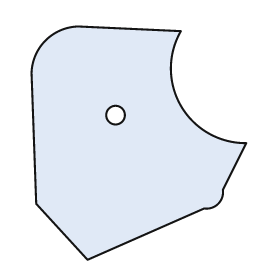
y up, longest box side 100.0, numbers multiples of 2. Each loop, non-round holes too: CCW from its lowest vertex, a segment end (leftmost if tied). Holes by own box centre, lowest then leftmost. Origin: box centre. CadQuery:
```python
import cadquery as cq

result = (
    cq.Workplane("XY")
    .moveTo(-22.0, -50.0)
    .lineTo(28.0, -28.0)
    .threePointArc((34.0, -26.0), (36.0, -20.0))
    .lineTo(46.0, 0.0)
    .threePointArc((18.0, 16.0), (18.0, 48.0))
    .lineTo(-26.0, 50.0)
    .threePointArc((-40.0, 44.0), (-46.0, 30.0))
    .lineTo(-44.0, -26.0)
    .close()
    .moveTo(-10.0, 12.0)
    .circle(4.0)
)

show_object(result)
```